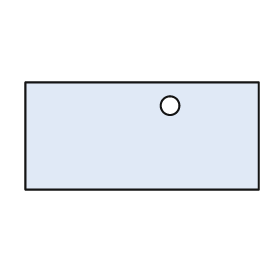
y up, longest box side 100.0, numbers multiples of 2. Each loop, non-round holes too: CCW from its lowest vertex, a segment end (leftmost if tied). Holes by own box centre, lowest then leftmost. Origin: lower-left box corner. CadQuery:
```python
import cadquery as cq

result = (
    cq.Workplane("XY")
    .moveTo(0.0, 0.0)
    .lineTo(100.0, 0.0)
    .lineTo(100.0, 46.0)
    .lineTo(0.0, 46.0)
    .close()
    .moveTo(62.0, 36.0)
    .circle(4.0)
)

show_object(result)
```